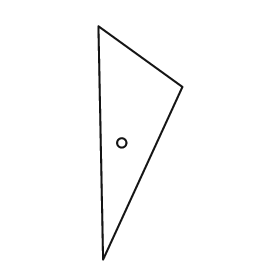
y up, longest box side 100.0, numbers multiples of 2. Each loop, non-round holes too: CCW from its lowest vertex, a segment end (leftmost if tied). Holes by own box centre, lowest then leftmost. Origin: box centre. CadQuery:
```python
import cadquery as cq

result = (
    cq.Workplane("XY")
    .moveTo(-16.0, -50.0)
    .lineTo(18.0, 24.0)
    .lineTo(-18.0, 50.0)
    .close()
    .moveTo(-8.0, 0.0)
    .circle(2.0)
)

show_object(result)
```